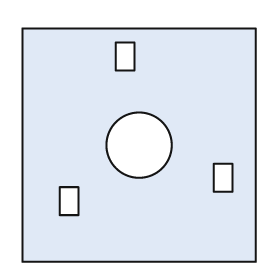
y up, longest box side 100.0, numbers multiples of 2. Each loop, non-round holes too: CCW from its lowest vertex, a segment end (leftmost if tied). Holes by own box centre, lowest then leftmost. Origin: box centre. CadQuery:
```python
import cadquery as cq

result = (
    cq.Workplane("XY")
    .moveTo(-50.0, -50.0)
    .lineTo(50.0, -50.0)
    .lineTo(50.0, 50.0)
    .lineTo(-50.0, 50.0)
    .close()
    .moveTo(-34.0, -30.0)
    .lineTo(-26.0, -30.0)
    .lineTo(-26.0, -18.0)
    .lineTo(-34.0, -18.0)
    .close()
    .moveTo(32.0, -20.0)
    .lineTo(40.0, -20.0)
    .lineTo(40.0, -8.0)
    .lineTo(32.0, -8.0)
    .close()
    .moveTo(0.0, 0.0)
    .circle(14.0)
    .moveTo(-10.0, 32.0)
    .lineTo(-2.0, 32.0)
    .lineTo(-2.0, 44.0)
    .lineTo(-10.0, 44.0)
    .close()
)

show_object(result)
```